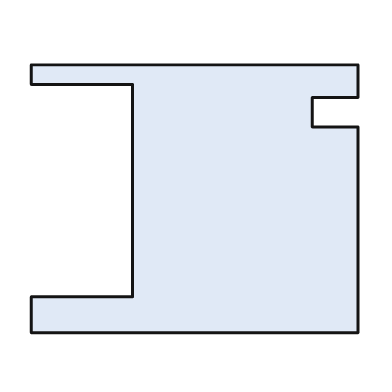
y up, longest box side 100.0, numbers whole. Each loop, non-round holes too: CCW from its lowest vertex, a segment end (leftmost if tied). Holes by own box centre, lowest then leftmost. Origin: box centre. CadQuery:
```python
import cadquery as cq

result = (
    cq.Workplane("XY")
    .moveTo(-50.0, -41.0)
    .lineTo(50.0, -41.0)
    .lineTo(50.0, 22.0)
    .lineTo(36.0, 22.0)
    .lineTo(36.0, 31.0)
    .lineTo(50.0, 31.0)
    .lineTo(50.0, 41.0)
    .lineTo(-50.0, 41.0)
    .lineTo(-50.0, 35.0)
    .lineTo(-19.0, 35.0)
    .lineTo(-19.0, -30.0)
    .lineTo(-50.0, -30.0)
    .close()
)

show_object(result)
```